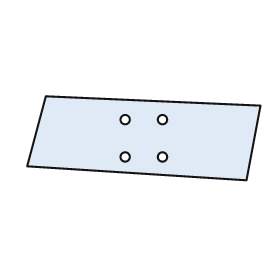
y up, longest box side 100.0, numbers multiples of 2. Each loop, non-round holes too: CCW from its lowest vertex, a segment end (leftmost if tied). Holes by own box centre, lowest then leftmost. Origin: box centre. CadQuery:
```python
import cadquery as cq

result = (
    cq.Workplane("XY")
    .moveTo(44.0, -18.0)
    .lineTo(50.0, 14.0)
    .lineTo(-42.0, 18.0)
    .lineTo(-50.0, -12.0)
    .close()
    .moveTo(-8.0, -8.0)
    .circle(2.0)
    .moveTo(8.0, -8.0)
    .circle(2.0)
    .moveTo(-8.0, 8.0)
    .circle(2.0)
    .moveTo(8.0, 8.0)
    .circle(2.0)
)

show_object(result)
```